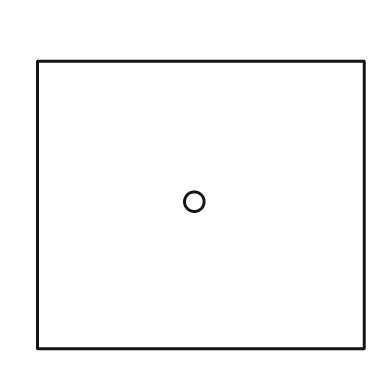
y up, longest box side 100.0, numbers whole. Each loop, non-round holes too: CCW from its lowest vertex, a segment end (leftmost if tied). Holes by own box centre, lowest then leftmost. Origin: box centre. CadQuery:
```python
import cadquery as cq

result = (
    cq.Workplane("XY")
    .moveTo(-50.0, -44.0)
    .lineTo(50.0, -44.0)
    .lineTo(50.0, 44.0)
    .lineTo(-50.0, 44.0)
    .close()
    .moveTo(-2.0, 1.0)
    .circle(3.0)
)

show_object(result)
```